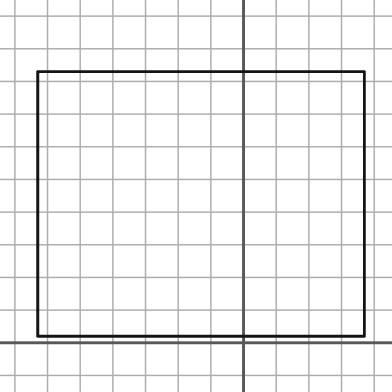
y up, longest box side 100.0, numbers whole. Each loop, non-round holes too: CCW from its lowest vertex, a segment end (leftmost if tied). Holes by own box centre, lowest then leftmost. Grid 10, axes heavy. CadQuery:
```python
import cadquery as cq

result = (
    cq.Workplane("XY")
    .moveTo(-63.0, 2.0)
    .lineTo(37.0, 2.0)
    .lineTo(37.0, 83.0)
    .lineTo(-63.0, 83.0)
    .close()
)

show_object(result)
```